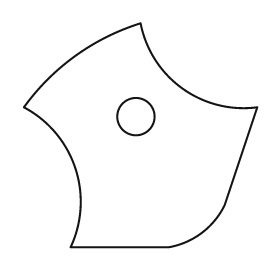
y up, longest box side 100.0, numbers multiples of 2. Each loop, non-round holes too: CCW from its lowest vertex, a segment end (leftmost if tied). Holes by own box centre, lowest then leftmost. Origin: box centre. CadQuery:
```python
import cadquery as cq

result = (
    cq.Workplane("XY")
    .moveTo(-30.0, -48.0)
    .lineTo(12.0, -48.0)
    .threePointArc((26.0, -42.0), (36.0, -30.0))
    .lineTo(50.0, 12.0)
    .threePointArc((18.0, 20.0), (0.0, 48.0))
    .threePointArc((-28.0, 34.0), (-50.0, 12.0))
    .threePointArc((-28.0, -14.0), (-30.0, -48.0))
    .close()
    .moveTo(-2.0, 8.0)
    .circle(8.0)
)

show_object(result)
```